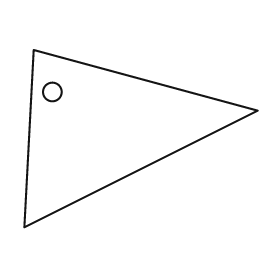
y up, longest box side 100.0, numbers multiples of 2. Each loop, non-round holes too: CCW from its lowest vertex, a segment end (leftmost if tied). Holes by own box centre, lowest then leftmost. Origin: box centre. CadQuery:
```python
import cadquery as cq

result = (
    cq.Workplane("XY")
    .moveTo(-50.0, -38.0)
    .lineTo(50.0, 12.0)
    .lineTo(-46.0, 38.0)
    .close()
    .moveTo(-38.0, 20.0)
    .circle(4.0)
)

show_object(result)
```